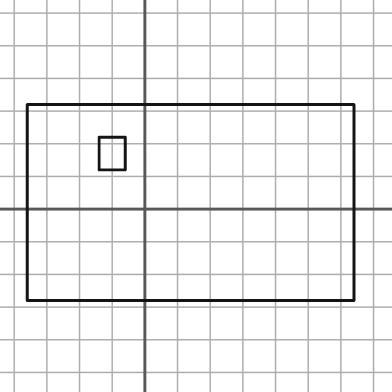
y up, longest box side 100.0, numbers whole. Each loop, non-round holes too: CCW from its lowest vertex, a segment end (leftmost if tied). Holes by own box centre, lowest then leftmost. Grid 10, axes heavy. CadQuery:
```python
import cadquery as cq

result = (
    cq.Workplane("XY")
    .moveTo(-36.0, -28.0)
    .lineTo(64.0, -28.0)
    .lineTo(64.0, 32.0)
    .lineTo(-36.0, 32.0)
    .close()
    .moveTo(-14.0, 12.0)
    .lineTo(-6.0, 12.0)
    .lineTo(-6.0, 22.0)
    .lineTo(-14.0, 22.0)
    .close()
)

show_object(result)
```